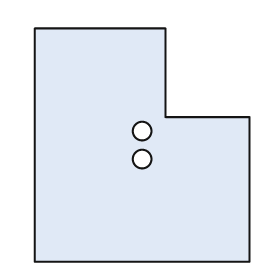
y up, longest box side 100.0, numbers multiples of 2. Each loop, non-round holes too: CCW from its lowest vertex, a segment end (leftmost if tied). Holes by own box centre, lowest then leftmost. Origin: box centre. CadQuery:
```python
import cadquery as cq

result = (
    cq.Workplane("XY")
    .moveTo(-46.0, -50.0)
    .lineTo(46.0, -50.0)
    .lineTo(46.0, 12.0)
    .lineTo(10.0, 12.0)
    .lineTo(10.0, 50.0)
    .lineTo(-46.0, 50.0)
    .close()
    .moveTo(0.0, -6.0)
    .circle(4.0)
    .moveTo(0.0, 6.0)
    .circle(4.0)
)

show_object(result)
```